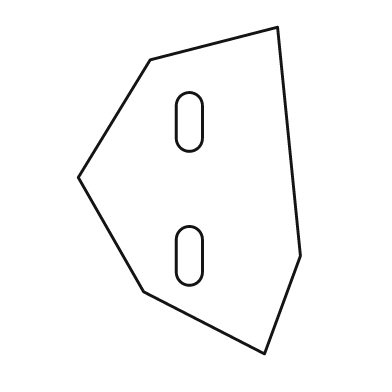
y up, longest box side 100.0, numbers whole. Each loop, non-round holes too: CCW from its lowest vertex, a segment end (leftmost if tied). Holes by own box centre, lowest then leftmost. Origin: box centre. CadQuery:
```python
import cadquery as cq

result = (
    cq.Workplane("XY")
    .moveTo(23.0, -50.0)
    .lineTo(34.0, -20.0)
    .lineTo(27.0, 50.0)
    .lineTo(-12.0, 40.0)
    .lineTo(-34.0, 4.0)
    .lineTo(-14.0, -31.0)
    .close()
    .moveTo(-4.0, -25.0)
    .threePointArc((0.0, -29.0), (4.0, -25.0))
    .lineTo(4.0, -15.0)
    .threePointArc((0.0, -11.0), (-4.0, -15.0))
    .close()
    .moveTo(-4.0, 16.0)
    .threePointArc((0.0, 12.0), (4.0, 16.0))
    .lineTo(4.0, 26.0)
    .threePointArc((0.0, 30.0), (-4.0, 26.0))
    .close()
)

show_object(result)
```